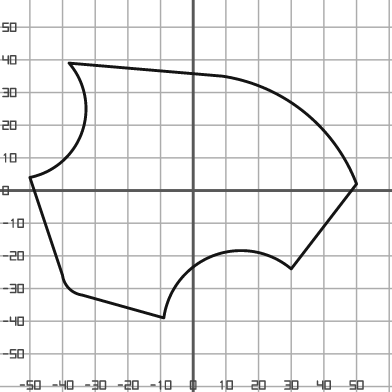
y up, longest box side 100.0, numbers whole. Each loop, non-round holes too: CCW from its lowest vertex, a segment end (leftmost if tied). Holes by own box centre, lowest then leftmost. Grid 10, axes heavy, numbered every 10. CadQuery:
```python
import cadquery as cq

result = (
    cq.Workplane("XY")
    .moveTo(-9.0, -39.0)
    .threePointArc((6.0, -20.0), (30.0, -24.0))
    .lineTo(50.0, 2.0)
    .threePointArc((34.0, 24.0), (9.0, 35.0))
    .lineTo(-38.0, 39.0)
    .threePointArc((-34.0, 18.0), (-50.0, 4.0))
    .lineTo(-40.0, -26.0)
    .threePointArc((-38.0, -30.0), (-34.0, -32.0))
    .close()
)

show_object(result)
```